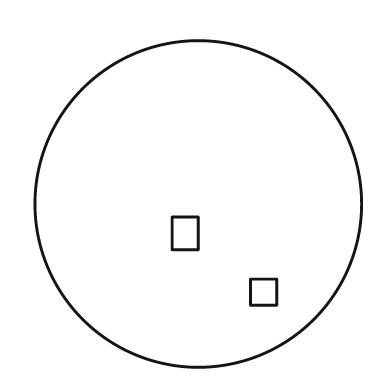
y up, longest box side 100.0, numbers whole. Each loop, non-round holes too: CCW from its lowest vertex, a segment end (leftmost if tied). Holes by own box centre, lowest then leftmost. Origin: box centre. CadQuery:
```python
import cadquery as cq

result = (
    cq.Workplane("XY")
    .moveTo(0.0, 0.0)
    .circle(50.0)
    .moveTo(16.0, -31.0)
    .lineTo(24.0, -31.0)
    .lineTo(24.0, -23.0)
    .lineTo(16.0, -23.0)
    .close()
    .moveTo(-8.0, -14.0)
    .lineTo(0.0, -14.0)
    .lineTo(0.0, -4.0)
    .lineTo(-8.0, -4.0)
    .close()
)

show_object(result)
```